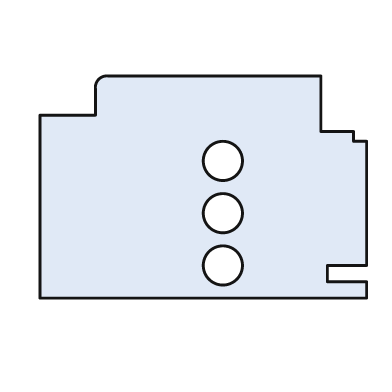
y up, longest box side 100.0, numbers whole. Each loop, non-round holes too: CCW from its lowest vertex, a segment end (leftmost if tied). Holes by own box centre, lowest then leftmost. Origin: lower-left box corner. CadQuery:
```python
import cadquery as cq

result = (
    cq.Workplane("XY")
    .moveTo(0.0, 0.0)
    .lineTo(100.0, 0.0)
    .lineTo(100.0, 5.0)
    .lineTo(88.0, 5.0)
    .lineTo(88.0, 10.0)
    .lineTo(100.0, 10.0)
    .lineTo(100.0, 48.0)
    .lineTo(96.0, 48.0)
    .lineTo(96.0, 51.0)
    .lineTo(86.0, 51.0)
    .lineTo(86.0, 68.0)
    .lineTo(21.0, 68.0)
    .threePointArc((18.0, 67.0), (17.0, 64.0))
    .lineTo(17.0, 56.0)
    .lineTo(0.0, 56.0)
    .close()
    .moveTo(56.0, 10.0)
    .circle(6.0)
    .moveTo(56.0, 26.0)
    .circle(6.0)
    .moveTo(56.0, 42.0)
    .circle(6.0)
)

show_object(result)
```